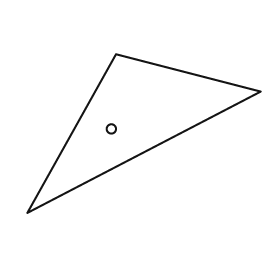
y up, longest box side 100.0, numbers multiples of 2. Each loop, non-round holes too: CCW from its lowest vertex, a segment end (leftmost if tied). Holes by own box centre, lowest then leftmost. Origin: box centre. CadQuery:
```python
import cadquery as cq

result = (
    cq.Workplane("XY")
    .moveTo(-50.0, -34.0)
    .lineTo(50.0, 18.0)
    .lineTo(-12.0, 34.0)
    .close()
    .moveTo(-14.0, 2.0)
    .circle(2.0)
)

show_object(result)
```